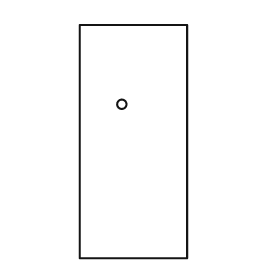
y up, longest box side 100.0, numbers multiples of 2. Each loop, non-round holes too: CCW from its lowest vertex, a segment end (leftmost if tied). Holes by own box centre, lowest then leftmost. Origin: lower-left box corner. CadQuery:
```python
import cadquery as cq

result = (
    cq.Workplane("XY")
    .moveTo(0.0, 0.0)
    .lineTo(46.0, 0.0)
    .lineTo(46.0, 100.0)
    .lineTo(0.0, 100.0)
    .close()
    .moveTo(18.0, 66.0)
    .circle(2.0)
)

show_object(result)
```